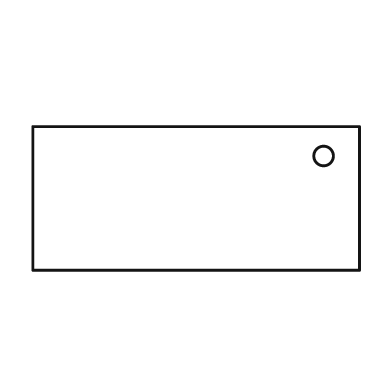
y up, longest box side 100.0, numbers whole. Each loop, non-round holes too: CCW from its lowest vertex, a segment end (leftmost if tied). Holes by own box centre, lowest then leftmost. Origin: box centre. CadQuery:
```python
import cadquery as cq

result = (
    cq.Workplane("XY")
    .moveTo(-50.0, -22.0)
    .lineTo(50.0, -22.0)
    .lineTo(50.0, 22.0)
    .lineTo(-50.0, 22.0)
    .close()
    .moveTo(39.0, 13.0)
    .circle(3.0)
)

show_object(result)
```